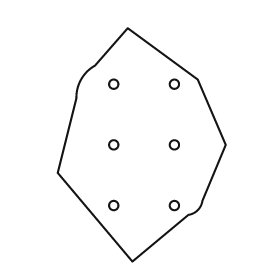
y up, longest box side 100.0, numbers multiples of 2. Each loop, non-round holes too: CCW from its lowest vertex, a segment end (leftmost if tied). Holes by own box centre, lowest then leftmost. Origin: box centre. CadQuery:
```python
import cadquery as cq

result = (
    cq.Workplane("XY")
    .moveTo(-4.0, -50.0)
    .lineTo(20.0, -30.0)
    .threePointArc((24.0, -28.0), (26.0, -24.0))
    .lineTo(36.0, 0.0)
    .lineTo(24.0, 28.0)
    .lineTo(-6.0, 50.0)
    .lineTo(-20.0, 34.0)
    .threePointArc((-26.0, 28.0), (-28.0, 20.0))
    .lineTo(-36.0, -12.0)
    .close()
    .moveTo(-12.0, -26.0)
    .circle(2.0)
    .moveTo(14.0, -26.0)
    .circle(2.0)
    .moveTo(-12.0, 0.0)
    .circle(2.0)
    .moveTo(14.0, 0.0)
    .circle(2.0)
    .moveTo(-12.0, 26.0)
    .circle(2.0)
    .moveTo(14.0, 26.0)
    .circle(2.0)
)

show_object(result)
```